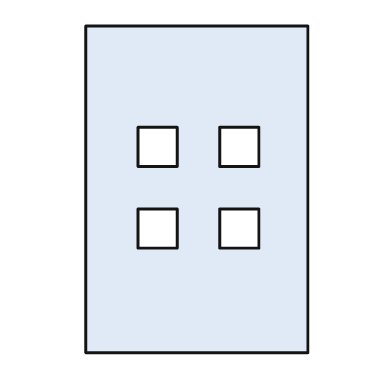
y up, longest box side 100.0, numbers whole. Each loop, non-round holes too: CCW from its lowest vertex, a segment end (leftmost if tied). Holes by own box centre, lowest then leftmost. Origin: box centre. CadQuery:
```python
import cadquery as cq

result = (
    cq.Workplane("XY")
    .moveTo(-34.0, -50.0)
    .lineTo(34.0, -50.0)
    .lineTo(34.0, 50.0)
    .lineTo(-34.0, 50.0)
    .close()
    .moveTo(-18.0, -18.0)
    .lineTo(-6.0, -18.0)
    .lineTo(-6.0, -6.0)
    .lineTo(-18.0, -6.0)
    .close()
    .moveTo(7.0, -18.0)
    .lineTo(19.0, -18.0)
    .lineTo(19.0, -6.0)
    .lineTo(7.0, -6.0)
    .close()
    .moveTo(-18.0, 7.0)
    .lineTo(-6.0, 7.0)
    .lineTo(-6.0, 19.0)
    .lineTo(-18.0, 19.0)
    .close()
    .moveTo(7.0, 7.0)
    .lineTo(19.0, 7.0)
    .lineTo(19.0, 19.0)
    .lineTo(7.0, 19.0)
    .close()
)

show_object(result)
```